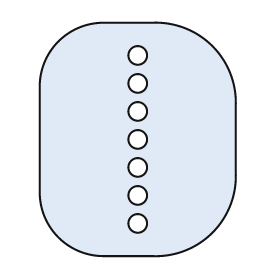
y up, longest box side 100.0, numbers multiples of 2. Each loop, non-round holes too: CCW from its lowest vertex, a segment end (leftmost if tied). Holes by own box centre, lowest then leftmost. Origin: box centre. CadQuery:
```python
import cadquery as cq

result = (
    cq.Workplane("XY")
    .moveTo(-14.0, -50.0)
    .lineTo(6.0, -50.0)
    .threePointArc((32.0, -40.0), (42.0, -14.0))
    .lineTo(42.0, 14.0)
    .threePointArc((32.0, 40.0), (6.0, 50.0))
    .lineTo(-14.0, 50.0)
    .threePointArc((-34.0, 42.0), (-42.0, 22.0))
    .lineTo(-42.0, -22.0)
    .threePointArc((-34.0, -42.0), (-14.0, -50.0))
    .close()
    .moveTo(0.0, -36.0)
    .circle(4.0)
    .moveTo(0.0, -24.0)
    .circle(4.0)
    .moveTo(0.0, -12.0)
    .circle(4.0)
    .moveTo(0.0, 0.0)
    .circle(4.0)
    .moveTo(0.0, 12.0)
    .circle(4.0)
    .moveTo(0.0, 24.0)
    .circle(4.0)
    .moveTo(0.0, 36.0)
    .circle(4.0)
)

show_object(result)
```